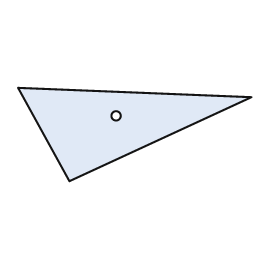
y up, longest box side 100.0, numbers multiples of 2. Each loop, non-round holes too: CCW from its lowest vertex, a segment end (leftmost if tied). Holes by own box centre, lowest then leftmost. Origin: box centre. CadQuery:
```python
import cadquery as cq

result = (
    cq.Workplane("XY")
    .moveTo(-28.0, -20.0)
    .lineTo(50.0, 16.0)
    .lineTo(-50.0, 20.0)
    .close()
    .moveTo(-8.0, 8.0)
    .circle(2.0)
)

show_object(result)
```